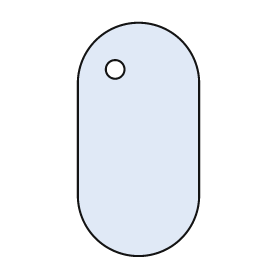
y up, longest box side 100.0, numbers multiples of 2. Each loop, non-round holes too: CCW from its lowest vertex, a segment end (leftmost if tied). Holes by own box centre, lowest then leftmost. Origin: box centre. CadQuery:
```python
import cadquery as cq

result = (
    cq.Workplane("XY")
    .moveTo(-26.0, -24.0)
    .threePointArc((0.0, -50.0), (26.0, -24.0))
    .lineTo(26.0, 24.0)
    .threePointArc((0.0, 50.0), (-26.0, 24.0))
    .close()
    .moveTo(-10.0, 30.0)
    .circle(4.0)
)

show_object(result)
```